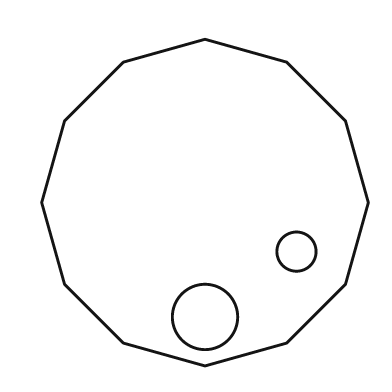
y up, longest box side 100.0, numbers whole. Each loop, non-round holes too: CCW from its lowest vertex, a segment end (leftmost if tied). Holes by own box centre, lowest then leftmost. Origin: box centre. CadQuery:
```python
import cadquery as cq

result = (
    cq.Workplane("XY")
    .moveTo(0.0, -50.0)
    .lineTo(25.0, -43.0)
    .lineTo(43.0, -25.0)
    .lineTo(50.0, 0.0)
    .lineTo(43.0, 25.0)
    .lineTo(25.0, 43.0)
    .lineTo(0.0, 50.0)
    .lineTo(-25.0, 43.0)
    .lineTo(-43.0, 25.0)
    .lineTo(-50.0, 0.0)
    .lineTo(-43.0, -25.0)
    .lineTo(-25.0, -43.0)
    .close()
    .moveTo(0.0, -35.0)
    .circle(10.0)
    .moveTo(28.0, -15.0)
    .circle(6.0)
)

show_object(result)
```